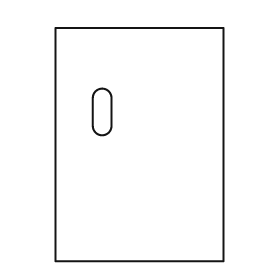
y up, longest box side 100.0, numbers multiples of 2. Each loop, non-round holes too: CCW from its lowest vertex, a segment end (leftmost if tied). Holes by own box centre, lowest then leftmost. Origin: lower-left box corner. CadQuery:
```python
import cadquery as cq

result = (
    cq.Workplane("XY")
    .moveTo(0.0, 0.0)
    .lineTo(72.0, 0.0)
    .lineTo(72.0, 100.0)
    .lineTo(0.0, 100.0)
    .close()
    .moveTo(16.0, 58.0)
    .threePointArc((20.0, 54.0), (24.0, 58.0))
    .lineTo(24.0, 70.0)
    .threePointArc((20.0, 74.0), (16.0, 70.0))
    .close()
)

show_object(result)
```